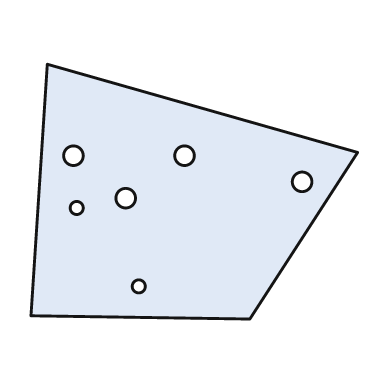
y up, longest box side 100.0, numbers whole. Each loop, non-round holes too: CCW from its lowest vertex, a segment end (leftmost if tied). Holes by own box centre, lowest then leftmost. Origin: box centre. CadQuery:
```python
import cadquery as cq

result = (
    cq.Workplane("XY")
    .moveTo(17.0, -39.0)
    .lineTo(50.0, 12.0)
    .lineTo(-45.0, 39.0)
    .lineTo(-50.0, -38.0)
    .close()
    .moveTo(-17.0, -29.0)
    .circle(2.0)
    .moveTo(-36.0, -5.0)
    .circle(2.0)
    .moveTo(-21.0, -2.0)
    .circle(3.0)
    .moveTo(33.0, 3.0)
    .circle(3.0)
    .moveTo(-37.0, 11.0)
    .circle(3.0)
    .moveTo(-3.0, 11.0)
    .circle(3.0)
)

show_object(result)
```